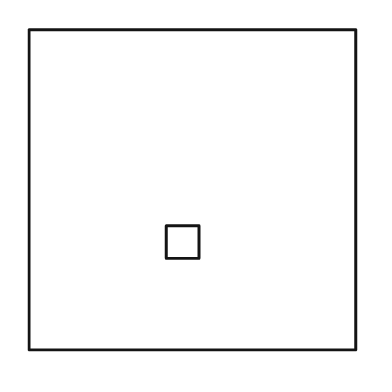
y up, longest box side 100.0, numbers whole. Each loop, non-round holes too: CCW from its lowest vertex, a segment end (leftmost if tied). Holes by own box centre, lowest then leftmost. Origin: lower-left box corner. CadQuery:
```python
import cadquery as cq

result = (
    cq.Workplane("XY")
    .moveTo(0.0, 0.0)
    .lineTo(100.0, 0.0)
    .lineTo(100.0, 98.0)
    .lineTo(0.0, 98.0)
    .close()
    .moveTo(42.0, 28.0)
    .lineTo(52.0, 28.0)
    .lineTo(52.0, 38.0)
    .lineTo(42.0, 38.0)
    .close()
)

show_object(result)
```